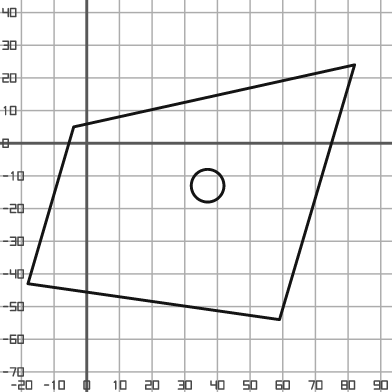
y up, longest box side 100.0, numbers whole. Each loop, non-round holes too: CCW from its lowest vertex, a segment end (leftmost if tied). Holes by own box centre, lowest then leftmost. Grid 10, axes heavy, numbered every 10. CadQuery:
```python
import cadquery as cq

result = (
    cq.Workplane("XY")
    .moveTo(59.0, -54.0)
    .lineTo(82.0, 24.0)
    .lineTo(-4.0, 5.0)
    .lineTo(-18.0, -43.0)
    .close()
    .moveTo(37.0, -13.0)
    .circle(5.0)
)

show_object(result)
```